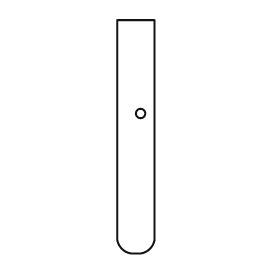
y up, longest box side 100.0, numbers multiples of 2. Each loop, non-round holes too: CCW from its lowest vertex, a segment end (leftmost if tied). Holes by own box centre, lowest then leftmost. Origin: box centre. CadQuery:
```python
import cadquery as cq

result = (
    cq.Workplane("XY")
    .moveTo(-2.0, -50.0)
    .lineTo(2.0, -50.0)
    .threePointArc((6.0, -48.0), (8.0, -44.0))
    .lineTo(8.0, 50.0)
    .lineTo(-8.0, 50.0)
    .lineTo(-8.0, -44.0)
    .threePointArc((-6.0, -48.0), (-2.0, -50.0))
    .close()
    .moveTo(2.0, 10.0)
    .circle(2.0)
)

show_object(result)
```